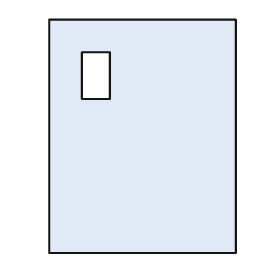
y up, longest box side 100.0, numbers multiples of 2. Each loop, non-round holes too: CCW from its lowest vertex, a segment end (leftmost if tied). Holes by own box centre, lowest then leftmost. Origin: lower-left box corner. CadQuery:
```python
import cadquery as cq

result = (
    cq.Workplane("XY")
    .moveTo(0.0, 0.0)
    .lineTo(80.0, 0.0)
    .lineTo(80.0, 100.0)
    .lineTo(0.0, 100.0)
    .close()
    .moveTo(14.0, 66.0)
    .lineTo(26.0, 66.0)
    .lineTo(26.0, 86.0)
    .lineTo(14.0, 86.0)
    .close()
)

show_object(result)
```